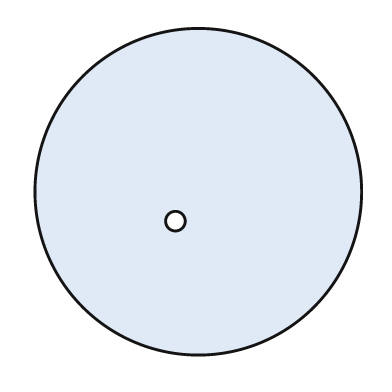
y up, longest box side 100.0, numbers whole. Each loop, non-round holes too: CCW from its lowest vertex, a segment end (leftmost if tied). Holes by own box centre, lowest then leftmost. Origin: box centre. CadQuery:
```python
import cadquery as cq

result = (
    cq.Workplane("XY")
    .moveTo(0.0, 0.0)
    .circle(50.0)
    .moveTo(-7.0, -9.0)
    .circle(3.0)
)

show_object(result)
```